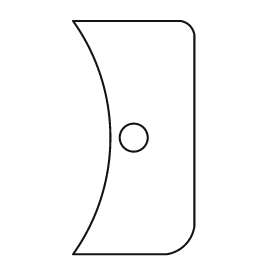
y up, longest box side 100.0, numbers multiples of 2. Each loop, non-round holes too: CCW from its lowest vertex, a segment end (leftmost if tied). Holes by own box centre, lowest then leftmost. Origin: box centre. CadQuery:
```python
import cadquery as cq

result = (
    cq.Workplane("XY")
    .moveTo(-26.0, -50.0)
    .lineTo(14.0, -50.0)
    .threePointArc((22.0, -46.0), (26.0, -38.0))
    .lineTo(26.0, 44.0)
    .threePointArc((24.0, 48.0), (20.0, 50.0))
    .lineTo(-26.0, 50.0)
    .threePointArc((-10.0, 0.0), (-26.0, -50.0))
    .close()
    .moveTo(0.0, 0.0)
    .circle(6.0)
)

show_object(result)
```